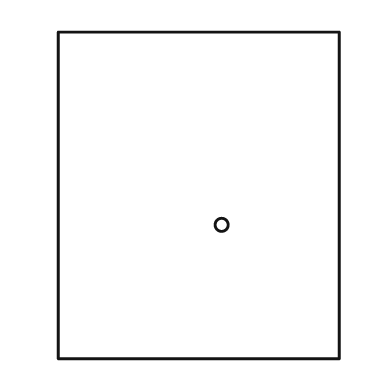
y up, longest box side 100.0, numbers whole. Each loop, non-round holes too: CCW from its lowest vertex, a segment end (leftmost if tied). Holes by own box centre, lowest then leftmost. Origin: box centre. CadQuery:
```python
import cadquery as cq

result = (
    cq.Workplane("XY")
    .moveTo(-43.0, -50.0)
    .lineTo(43.0, -50.0)
    .lineTo(43.0, 50.0)
    .lineTo(-43.0, 50.0)
    .close()
    .moveTo(7.0, -9.0)
    .circle(2.0)
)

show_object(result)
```